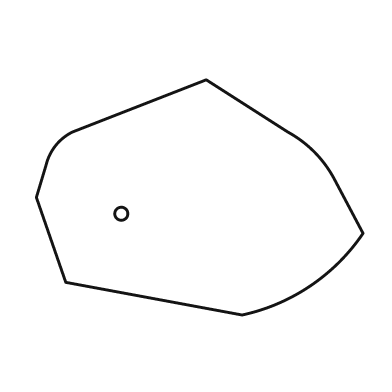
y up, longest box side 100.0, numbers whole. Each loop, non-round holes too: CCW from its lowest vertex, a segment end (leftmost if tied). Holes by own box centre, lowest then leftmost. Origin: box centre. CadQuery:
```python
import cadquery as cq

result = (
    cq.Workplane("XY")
    .moveTo(13.0, -36.0)
    .threePointArc((34.0, -27.0), (50.0, -11.0))
    .lineTo(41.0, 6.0)
    .threePointArc((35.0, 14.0), (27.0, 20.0))
    .lineTo(2.0, 36.0)
    .lineTo(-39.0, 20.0)
    .threePointArc((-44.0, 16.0), (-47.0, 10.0))
    .lineTo(-50.0, 0.0)
    .lineTo(-41.0, -26.0)
    .close()
    .moveTo(-24.0, -5.0)
    .circle(2.0)
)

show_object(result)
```